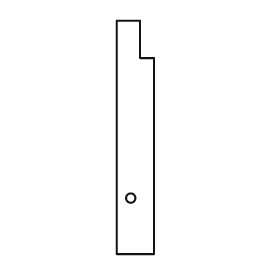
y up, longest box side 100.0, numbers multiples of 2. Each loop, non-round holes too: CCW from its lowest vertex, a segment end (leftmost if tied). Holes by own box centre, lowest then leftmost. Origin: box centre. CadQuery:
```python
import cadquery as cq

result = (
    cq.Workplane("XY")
    .moveTo(-8.0, -50.0)
    .lineTo(8.0, -50.0)
    .lineTo(8.0, 34.0)
    .lineTo(2.0, 34.0)
    .lineTo(2.0, 50.0)
    .lineTo(-8.0, 50.0)
    .close()
    .moveTo(-2.0, -26.0)
    .circle(2.0)
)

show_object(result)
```